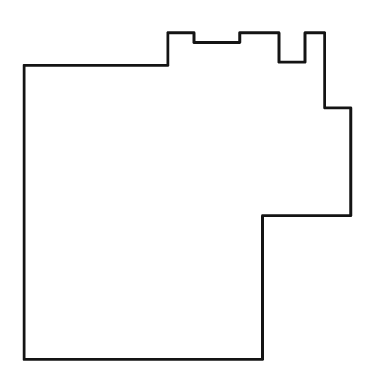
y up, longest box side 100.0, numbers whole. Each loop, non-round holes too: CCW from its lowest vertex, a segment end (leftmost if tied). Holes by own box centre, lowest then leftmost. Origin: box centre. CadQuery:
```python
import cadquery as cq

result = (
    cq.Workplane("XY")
    .moveTo(-50.0, -50.0)
    .lineTo(23.0, -50.0)
    .lineTo(23.0, -6.0)
    .lineTo(50.0, -6.0)
    .lineTo(50.0, 27.0)
    .lineTo(42.0, 27.0)
    .lineTo(42.0, 50.0)
    .lineTo(36.0, 50.0)
    .lineTo(36.0, 41.0)
    .lineTo(28.0, 41.0)
    .lineTo(28.0, 50.0)
    .lineTo(16.0, 50.0)
    .lineTo(16.0, 47.0)
    .lineTo(2.0, 47.0)
    .lineTo(2.0, 50.0)
    .lineTo(-6.0, 50.0)
    .lineTo(-6.0, 40.0)
    .lineTo(-50.0, 40.0)
    .close()
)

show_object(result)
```